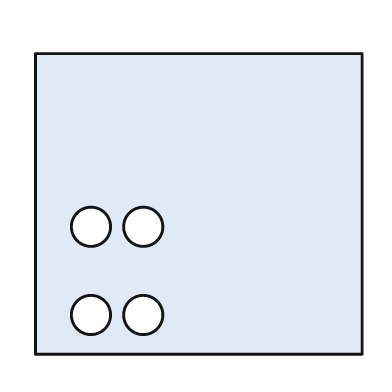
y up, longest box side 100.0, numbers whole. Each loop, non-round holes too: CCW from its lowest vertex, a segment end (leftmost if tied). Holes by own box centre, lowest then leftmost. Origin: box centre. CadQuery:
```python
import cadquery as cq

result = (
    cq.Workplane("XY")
    .moveTo(-50.0, -46.0)
    .lineTo(50.0, -46.0)
    .lineTo(50.0, 46.0)
    .lineTo(-50.0, 46.0)
    .close()
    .moveTo(-33.0, -34.0)
    .circle(6.0)
    .moveTo(-17.0, -34.0)
    .circle(6.0)
    .moveTo(-33.0, -7.0)
    .circle(6.0)
    .moveTo(-17.0, -7.0)
    .circle(6.0)
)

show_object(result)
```